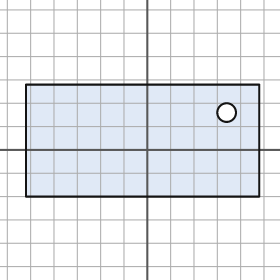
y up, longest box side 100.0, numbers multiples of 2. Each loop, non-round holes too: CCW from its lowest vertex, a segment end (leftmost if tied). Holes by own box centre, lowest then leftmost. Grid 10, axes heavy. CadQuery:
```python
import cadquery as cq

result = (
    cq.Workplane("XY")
    .moveTo(-52.0, -20.0)
    .lineTo(48.0, -20.0)
    .lineTo(48.0, 28.0)
    .lineTo(-52.0, 28.0)
    .close()
    .moveTo(34.0, 16.0)
    .circle(4.0)
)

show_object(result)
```